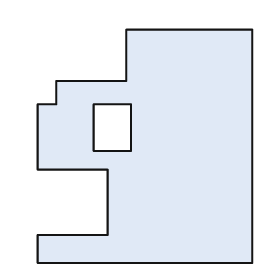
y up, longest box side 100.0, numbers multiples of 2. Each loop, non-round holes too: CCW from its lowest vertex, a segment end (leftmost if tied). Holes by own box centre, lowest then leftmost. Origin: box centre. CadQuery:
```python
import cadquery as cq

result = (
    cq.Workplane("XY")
    .moveTo(-46.0, -50.0)
    .lineTo(46.0, -50.0)
    .lineTo(46.0, 50.0)
    .lineTo(-8.0, 50.0)
    .lineTo(-8.0, 28.0)
    .lineTo(-38.0, 28.0)
    .lineTo(-38.0, 18.0)
    .lineTo(-46.0, 18.0)
    .lineTo(-46.0, -10.0)
    .lineTo(-16.0, -10.0)
    .lineTo(-16.0, -38.0)
    .lineTo(-46.0, -38.0)
    .close()
    .moveTo(-22.0, -2.0)
    .lineTo(-6.0, -2.0)
    .lineTo(-6.0, 18.0)
    .lineTo(-22.0, 18.0)
    .close()
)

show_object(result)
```